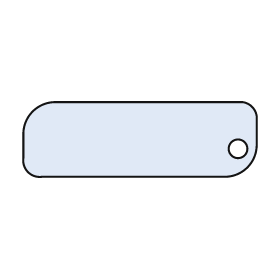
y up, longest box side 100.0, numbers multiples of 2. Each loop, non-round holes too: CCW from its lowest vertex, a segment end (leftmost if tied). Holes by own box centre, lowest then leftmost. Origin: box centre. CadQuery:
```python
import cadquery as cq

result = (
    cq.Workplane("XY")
    .moveTo(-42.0, -16.0)
    .lineTo(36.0, -16.0)
    .threePointArc((46.0, -12.0), (50.0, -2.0))
    .lineTo(50.0, 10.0)
    .threePointArc((48.0, 14.0), (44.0, 16.0))
    .lineTo(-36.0, 16.0)
    .threePointArc((-46.0, 12.0), (-50.0, 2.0))
    .lineTo(-50.0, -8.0)
    .threePointArc((-48.0, -14.0), (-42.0, -16.0))
    .close()
    .moveTo(42.0, -4.0)
    .circle(4.0)
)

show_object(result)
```